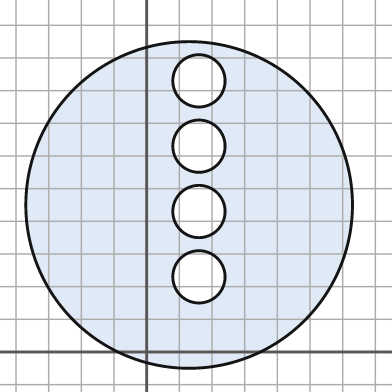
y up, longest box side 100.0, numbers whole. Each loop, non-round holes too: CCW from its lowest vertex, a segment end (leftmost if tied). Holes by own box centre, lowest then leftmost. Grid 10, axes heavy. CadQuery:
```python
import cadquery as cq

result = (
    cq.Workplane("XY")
    .moveTo(13.0, 45.0)
    .circle(50.0)
    .moveTo(16.0, 23.0)
    .circle(8.0)
    .moveTo(16.0, 43.0)
    .circle(8.0)
    .moveTo(16.0, 63.0)
    .circle(8.0)
    .moveTo(16.0, 83.0)
    .circle(8.0)
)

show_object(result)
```